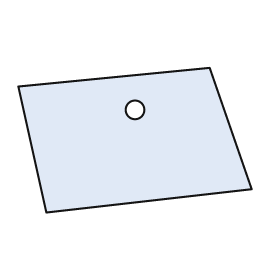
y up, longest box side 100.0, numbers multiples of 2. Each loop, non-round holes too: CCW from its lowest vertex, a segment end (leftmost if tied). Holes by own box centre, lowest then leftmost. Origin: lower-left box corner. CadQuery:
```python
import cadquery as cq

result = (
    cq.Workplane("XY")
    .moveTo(12.0, 0.0)
    .lineTo(100.0, 10.0)
    .lineTo(82.0, 62.0)
    .lineTo(0.0, 54.0)
    .close()
    .moveTo(50.0, 44.0)
    .circle(4.0)
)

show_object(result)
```